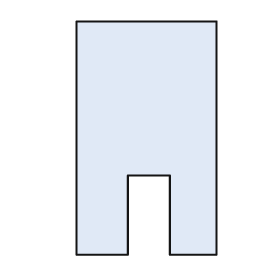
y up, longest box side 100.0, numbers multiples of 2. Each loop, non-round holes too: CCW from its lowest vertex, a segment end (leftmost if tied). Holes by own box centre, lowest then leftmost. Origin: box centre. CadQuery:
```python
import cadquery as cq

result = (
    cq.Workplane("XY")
    .moveTo(-30.0, -50.0)
    .lineTo(-8.0, -50.0)
    .lineTo(-8.0, -16.0)
    .lineTo(10.0, -16.0)
    .lineTo(10.0, -50.0)
    .lineTo(30.0, -50.0)
    .lineTo(30.0, 50.0)
    .lineTo(-30.0, 50.0)
    .close()
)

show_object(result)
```